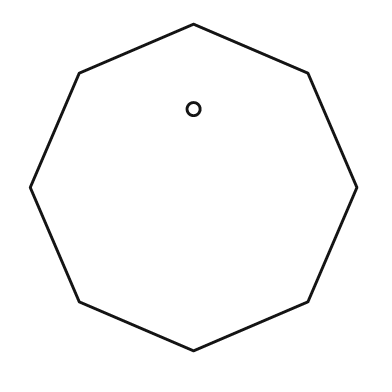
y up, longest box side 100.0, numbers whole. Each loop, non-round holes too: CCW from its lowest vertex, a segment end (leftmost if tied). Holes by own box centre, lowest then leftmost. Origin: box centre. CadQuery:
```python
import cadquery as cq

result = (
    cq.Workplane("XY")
    .moveTo(0.0, -50.0)
    .lineTo(35.0, -35.0)
    .lineTo(50.0, 0.0)
    .lineTo(35.0, 35.0)
    .lineTo(0.0, 50.0)
    .lineTo(-35.0, 35.0)
    .lineTo(-50.0, 0.0)
    .lineTo(-35.0, -35.0)
    .close()
    .moveTo(0.0, 24.0)
    .circle(2.0)
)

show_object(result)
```